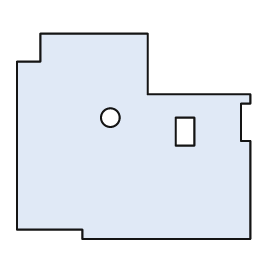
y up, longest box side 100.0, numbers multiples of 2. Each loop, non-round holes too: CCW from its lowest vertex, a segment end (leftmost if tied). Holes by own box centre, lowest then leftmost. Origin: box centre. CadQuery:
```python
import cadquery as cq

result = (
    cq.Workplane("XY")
    .moveTo(-22.0, -44.0)
    .lineTo(50.0, -44.0)
    .lineTo(50.0, -2.0)
    .lineTo(46.0, -2.0)
    .lineTo(46.0, 14.0)
    .lineTo(50.0, 14.0)
    .lineTo(50.0, 18.0)
    .lineTo(6.0, 18.0)
    .lineTo(6.0, 44.0)
    .lineTo(-40.0, 44.0)
    .lineTo(-40.0, 32.0)
    .lineTo(-50.0, 32.0)
    .lineTo(-50.0, -40.0)
    .lineTo(-22.0, -40.0)
    .close()
    .moveTo(18.0, -4.0)
    .lineTo(26.0, -4.0)
    .lineTo(26.0, 8.0)
    .lineTo(18.0, 8.0)
    .close()
    .moveTo(-10.0, 8.0)
    .circle(4.0)
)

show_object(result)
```